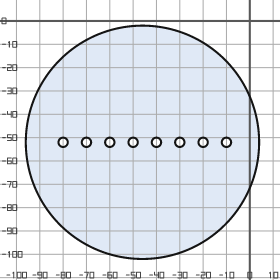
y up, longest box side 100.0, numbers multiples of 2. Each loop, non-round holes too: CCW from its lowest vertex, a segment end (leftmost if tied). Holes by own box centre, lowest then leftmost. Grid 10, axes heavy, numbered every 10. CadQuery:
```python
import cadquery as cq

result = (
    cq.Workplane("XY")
    .moveTo(-46.0, -52.0)
    .circle(50.0)
    .moveTo(-80.0, -52.0)
    .circle(2.0)
    .moveTo(-70.0, -52.0)
    .circle(2.0)
    .moveTo(-60.0, -52.0)
    .circle(2.0)
    .moveTo(-50.0, -52.0)
    .circle(2.0)
    .moveTo(-40.0, -52.0)
    .circle(2.0)
    .moveTo(-30.0, -52.0)
    .circle(2.0)
    .moveTo(-20.0, -52.0)
    .circle(2.0)
    .moveTo(-10.0, -52.0)
    .circle(2.0)
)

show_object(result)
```